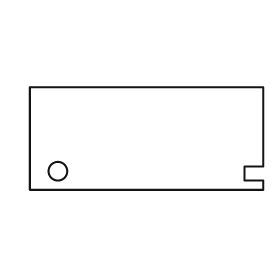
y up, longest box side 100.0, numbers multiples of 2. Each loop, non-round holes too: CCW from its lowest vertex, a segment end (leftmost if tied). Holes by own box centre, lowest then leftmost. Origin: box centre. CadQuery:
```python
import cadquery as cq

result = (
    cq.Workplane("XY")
    .moveTo(-50.0, -22.0)
    .lineTo(50.0, -22.0)
    .lineTo(50.0, -18.0)
    .lineTo(42.0, -18.0)
    .lineTo(42.0, -12.0)
    .lineTo(50.0, -12.0)
    .lineTo(50.0, 22.0)
    .lineTo(-50.0, 22.0)
    .close()
    .moveTo(-38.0, -14.0)
    .circle(4.0)
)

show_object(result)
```